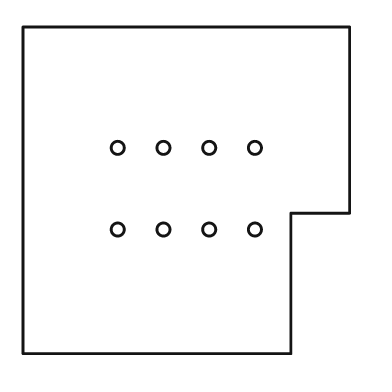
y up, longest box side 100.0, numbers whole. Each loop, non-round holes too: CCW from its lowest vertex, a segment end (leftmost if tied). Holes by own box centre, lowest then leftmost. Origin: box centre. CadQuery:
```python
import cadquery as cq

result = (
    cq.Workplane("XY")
    .moveTo(-50.0, -50.0)
    .lineTo(32.0, -50.0)
    .lineTo(32.0, -7.0)
    .lineTo(50.0, -7.0)
    .lineTo(50.0, 50.0)
    .lineTo(-50.0, 50.0)
    .close()
    .moveTo(-21.0, -12.0)
    .circle(2.0)
    .moveTo(-7.0, -12.0)
    .circle(2.0)
    .moveTo(7.0, -12.0)
    .circle(2.0)
    .moveTo(21.0, -12.0)
    .circle(2.0)
    .moveTo(-21.0, 13.0)
    .circle(2.0)
    .moveTo(-7.0, 13.0)
    .circle(2.0)
    .moveTo(7.0, 13.0)
    .circle(2.0)
    .moveTo(21.0, 13.0)
    .circle(2.0)
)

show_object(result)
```